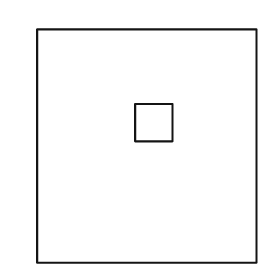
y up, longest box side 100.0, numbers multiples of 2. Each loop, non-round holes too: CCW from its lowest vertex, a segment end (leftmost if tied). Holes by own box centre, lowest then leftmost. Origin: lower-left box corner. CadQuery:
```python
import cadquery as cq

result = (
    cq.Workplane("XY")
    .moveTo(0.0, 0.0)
    .lineTo(94.0, 0.0)
    .lineTo(94.0, 100.0)
    .lineTo(0.0, 100.0)
    .close()
    .moveTo(42.0, 52.0)
    .lineTo(58.0, 52.0)
    .lineTo(58.0, 68.0)
    .lineTo(42.0, 68.0)
    .close()
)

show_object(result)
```